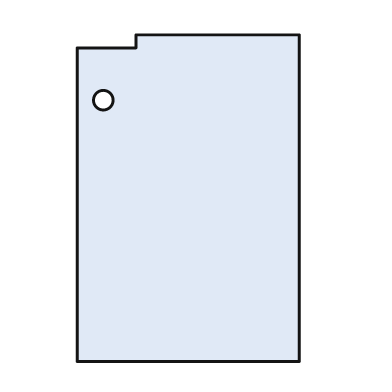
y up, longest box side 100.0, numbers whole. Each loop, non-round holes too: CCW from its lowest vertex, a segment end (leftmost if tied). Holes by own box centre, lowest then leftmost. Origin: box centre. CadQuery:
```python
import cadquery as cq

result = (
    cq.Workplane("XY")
    .moveTo(-34.0, -50.0)
    .lineTo(34.0, -50.0)
    .lineTo(34.0, 50.0)
    .lineTo(-16.0, 50.0)
    .lineTo(-16.0, 46.0)
    .lineTo(-34.0, 46.0)
    .close()
    .moveTo(-26.0, 30.0)
    .circle(3.0)
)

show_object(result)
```